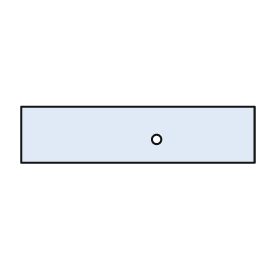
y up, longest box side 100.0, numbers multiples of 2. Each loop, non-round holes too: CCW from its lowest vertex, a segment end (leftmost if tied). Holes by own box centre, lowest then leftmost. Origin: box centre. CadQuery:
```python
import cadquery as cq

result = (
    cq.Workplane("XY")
    .moveTo(-50.0, -12.0)
    .lineTo(50.0, -12.0)
    .lineTo(50.0, 12.0)
    .lineTo(-50.0, 12.0)
    .close()
    .moveTo(8.0, -2.0)
    .circle(2.0)
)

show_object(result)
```